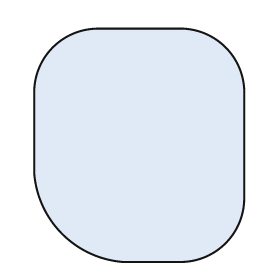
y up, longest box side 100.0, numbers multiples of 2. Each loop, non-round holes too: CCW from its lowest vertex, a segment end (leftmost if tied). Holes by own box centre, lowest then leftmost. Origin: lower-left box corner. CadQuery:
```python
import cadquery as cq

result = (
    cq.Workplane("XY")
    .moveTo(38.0, 0.0)
    .lineTo(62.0, 0.0)
    .threePointArc((82.0, 8.0), (90.0, 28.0))
    .lineTo(90.0, 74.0)
    .threePointArc((82.0, 92.0), (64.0, 100.0))
    .lineTo(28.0, 100.0)
    .threePointArc((8.0, 92.0), (0.0, 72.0))
    .lineTo(0.0, 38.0)
    .threePointArc((12.0, 12.0), (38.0, 0.0))
    .close()
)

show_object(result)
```